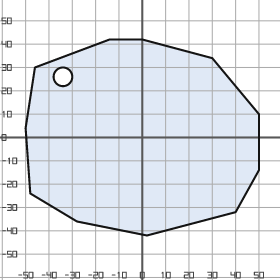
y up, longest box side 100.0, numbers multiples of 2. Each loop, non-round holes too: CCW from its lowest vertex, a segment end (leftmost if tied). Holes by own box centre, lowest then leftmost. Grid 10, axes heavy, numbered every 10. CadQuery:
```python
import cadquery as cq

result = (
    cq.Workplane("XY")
    .moveTo(2.0, -42.0)
    .lineTo(40.0, -32.0)
    .lineTo(50.0, -14.0)
    .lineTo(50.0, 10.0)
    .lineTo(30.0, 34.0)
    .lineTo(0.0, 42.0)
    .lineTo(-14.0, 42.0)
    .lineTo(-46.0, 30.0)
    .lineTo(-50.0, 4.0)
    .lineTo(-48.0, -24.0)
    .lineTo(-28.0, -36.0)
    .close()
    .moveTo(-34.0, 26.0)
    .circle(4.0)
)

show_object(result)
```